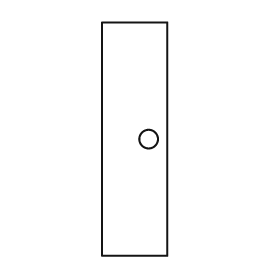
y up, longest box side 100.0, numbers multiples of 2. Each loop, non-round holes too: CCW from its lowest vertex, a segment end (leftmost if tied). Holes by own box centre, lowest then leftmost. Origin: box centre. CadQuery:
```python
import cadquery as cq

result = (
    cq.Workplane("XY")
    .moveTo(-14.0, -50.0)
    .lineTo(14.0, -50.0)
    .lineTo(14.0, 50.0)
    .lineTo(-14.0, 50.0)
    .close()
    .moveTo(6.0, 0.0)
    .circle(4.0)
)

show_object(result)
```